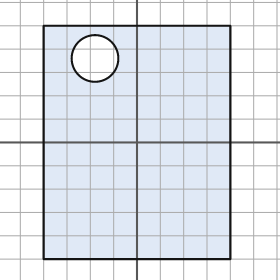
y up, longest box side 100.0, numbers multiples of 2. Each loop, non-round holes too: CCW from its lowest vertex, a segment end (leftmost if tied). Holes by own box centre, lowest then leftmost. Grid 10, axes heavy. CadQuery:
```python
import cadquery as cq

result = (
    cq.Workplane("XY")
    .moveTo(-40.0, -50.0)
    .lineTo(40.0, -50.0)
    .lineTo(40.0, 50.0)
    .lineTo(-40.0, 50.0)
    .close()
    .moveTo(-18.0, 36.0)
    .circle(10.0)
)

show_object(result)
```